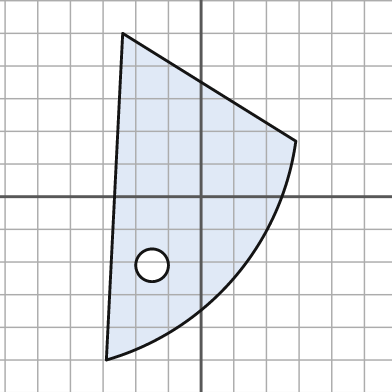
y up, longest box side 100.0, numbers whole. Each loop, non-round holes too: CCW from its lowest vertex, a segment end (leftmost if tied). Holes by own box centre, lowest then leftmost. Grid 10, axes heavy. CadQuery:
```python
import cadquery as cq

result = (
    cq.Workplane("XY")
    .moveTo(-29.0, -50.0)
    .threePointArc((10.0, -25.0), (29.0, 17.0))
    .lineTo(-24.0, 50.0)
    .close()
    .moveTo(-15.0, -21.0)
    .circle(5.0)
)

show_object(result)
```